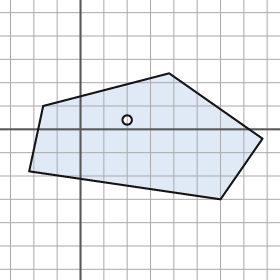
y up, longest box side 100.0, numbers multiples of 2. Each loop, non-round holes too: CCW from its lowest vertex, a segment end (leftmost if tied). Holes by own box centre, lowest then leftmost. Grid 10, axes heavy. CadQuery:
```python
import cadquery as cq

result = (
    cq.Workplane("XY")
    .moveTo(60.0, -30.0)
    .lineTo(78.0, -4.0)
    .lineTo(38.0, 24.0)
    .lineTo(-16.0, 10.0)
    .lineTo(-22.0, -18.0)
    .close()
    .moveTo(20.0, 4.0)
    .circle(2.0)
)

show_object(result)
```